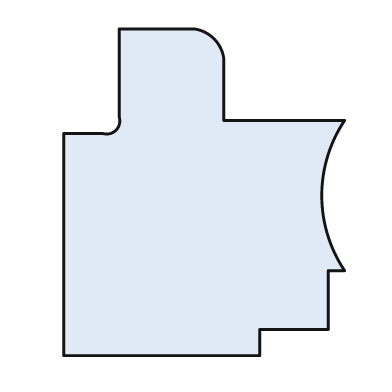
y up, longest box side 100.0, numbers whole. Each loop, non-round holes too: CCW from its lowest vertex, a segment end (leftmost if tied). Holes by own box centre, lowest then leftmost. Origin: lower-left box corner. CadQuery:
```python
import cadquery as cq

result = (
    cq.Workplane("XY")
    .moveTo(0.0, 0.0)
    .lineTo(60.0, 0.0)
    .lineTo(60.0, 8.0)
    .lineTo(81.0, 8.0)
    .lineTo(81.0, 26.0)
    .lineTo(86.0, 26.0)
    .threePointArc((79.0, 49.0), (86.0, 72.0))
    .lineTo(49.0, 72.0)
    .lineTo(49.0, 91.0)
    .threePointArc((46.0, 97.0), (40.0, 100.0))
    .lineTo(17.0, 100.0)
    .lineTo(17.0, 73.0)
    .threePointArc((16.0, 69.0), (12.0, 68.0))
    .lineTo(0.0, 68.0)
    .close()
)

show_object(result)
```